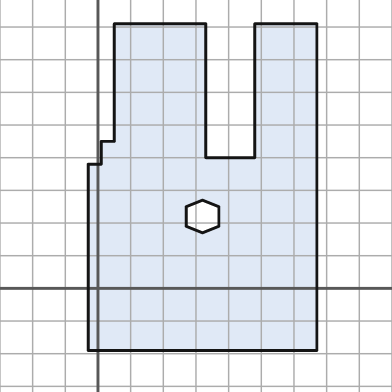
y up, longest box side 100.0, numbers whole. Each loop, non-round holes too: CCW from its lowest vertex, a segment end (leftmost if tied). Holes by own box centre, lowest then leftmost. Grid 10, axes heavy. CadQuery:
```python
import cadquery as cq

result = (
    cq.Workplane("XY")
    .moveTo(-3.0, -19.0)
    .lineTo(67.0, -19.0)
    .lineTo(67.0, 81.0)
    .lineTo(48.0, 81.0)
    .lineTo(48.0, 40.0)
    .lineTo(33.0, 40.0)
    .lineTo(33.0, 81.0)
    .lineTo(5.0, 81.0)
    .lineTo(5.0, 45.0)
    .lineTo(1.0, 45.0)
    .lineTo(1.0, 38.0)
    .lineTo(-3.0, 38.0)
    .close()
    .moveTo(32.0, 17.0)
    .lineTo(37.0, 19.0)
    .lineTo(37.0, 25.0)
    .lineTo(32.0, 27.0)
    .lineTo(27.0, 25.0)
    .lineTo(27.0, 19.0)
    .close()
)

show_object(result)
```